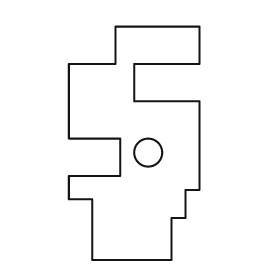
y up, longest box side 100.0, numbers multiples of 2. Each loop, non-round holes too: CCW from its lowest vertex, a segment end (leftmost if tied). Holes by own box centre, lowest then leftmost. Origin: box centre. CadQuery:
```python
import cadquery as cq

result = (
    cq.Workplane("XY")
    .moveTo(-18.0, -50.0)
    .lineTo(16.0, -50.0)
    .lineTo(16.0, -32.0)
    .lineTo(22.0, -32.0)
    .lineTo(22.0, -20.0)
    .lineTo(28.0, -20.0)
    .lineTo(28.0, 18.0)
    .lineTo(0.0, 18.0)
    .lineTo(0.0, 34.0)
    .lineTo(28.0, 34.0)
    .lineTo(28.0, 50.0)
    .lineTo(-8.0, 50.0)
    .lineTo(-8.0, 34.0)
    .lineTo(-28.0, 34.0)
    .lineTo(-28.0, 2.0)
    .lineTo(-6.0, 2.0)
    .lineTo(-6.0, -14.0)
    .lineTo(-28.0, -14.0)
    .lineTo(-28.0, -24.0)
    .lineTo(-18.0, -24.0)
    .close()
    .moveTo(6.0, -4.0)
    .circle(6.0)
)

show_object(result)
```